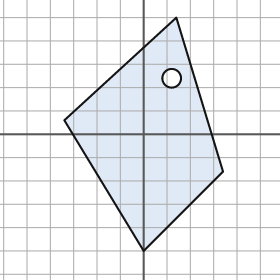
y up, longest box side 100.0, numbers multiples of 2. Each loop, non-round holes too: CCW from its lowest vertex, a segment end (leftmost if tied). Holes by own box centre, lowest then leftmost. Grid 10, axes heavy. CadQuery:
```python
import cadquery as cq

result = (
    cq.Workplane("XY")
    .moveTo(0.0, -50.0)
    .lineTo(34.0, -16.0)
    .lineTo(14.0, 50.0)
    .lineTo(-34.0, 6.0)
    .close()
    .moveTo(12.0, 24.0)
    .circle(4.0)
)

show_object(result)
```